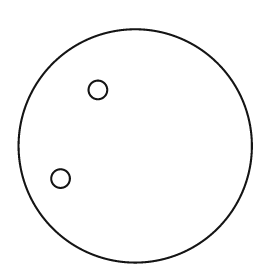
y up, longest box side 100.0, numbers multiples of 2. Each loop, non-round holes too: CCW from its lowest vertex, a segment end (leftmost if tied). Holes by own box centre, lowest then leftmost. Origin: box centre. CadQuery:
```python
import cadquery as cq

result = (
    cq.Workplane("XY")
    .moveTo(0.0, 0.0)
    .circle(50.0)
    .moveTo(-32.0, -14.0)
    .circle(4.0)
    .moveTo(-16.0, 24.0)
    .circle(4.0)
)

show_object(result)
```